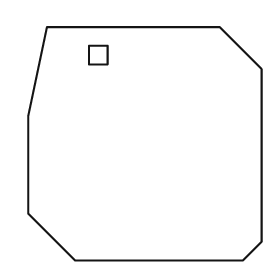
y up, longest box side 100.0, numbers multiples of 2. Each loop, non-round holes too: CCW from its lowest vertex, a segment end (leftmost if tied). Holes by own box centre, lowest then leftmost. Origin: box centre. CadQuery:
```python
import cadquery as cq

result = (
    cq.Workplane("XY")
    .moveTo(-30.0, -50.0)
    .lineTo(42.0, -50.0)
    .lineTo(50.0, -42.0)
    .lineTo(50.0, 32.0)
    .lineTo(32.0, 50.0)
    .lineTo(-42.0, 50.0)
    .lineTo(-50.0, 12.0)
    .lineTo(-50.0, -30.0)
    .close()
    .moveTo(-24.0, 34.0)
    .lineTo(-16.0, 34.0)
    .lineTo(-16.0, 42.0)
    .lineTo(-24.0, 42.0)
    .close()
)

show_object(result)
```